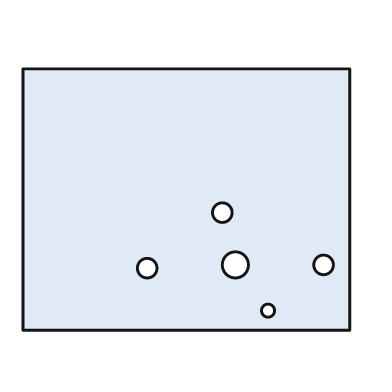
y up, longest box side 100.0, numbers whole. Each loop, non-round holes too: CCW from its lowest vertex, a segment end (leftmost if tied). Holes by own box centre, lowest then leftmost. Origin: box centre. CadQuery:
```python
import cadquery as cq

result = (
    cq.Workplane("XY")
    .moveTo(-50.0, -40.0)
    .lineTo(50.0, -40.0)
    .lineTo(50.0, 40.0)
    .lineTo(-50.0, 40.0)
    .close()
    .moveTo(25.0, -34.0)
    .circle(2.0)
    .moveTo(-12.0, -21.0)
    .circle(3.0)
    .moveTo(15.0, -20.0)
    .circle(4.0)
    .moveTo(42.0, -20.0)
    .circle(3.0)
    .moveTo(11.0, -4.0)
    .circle(3.0)
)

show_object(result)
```